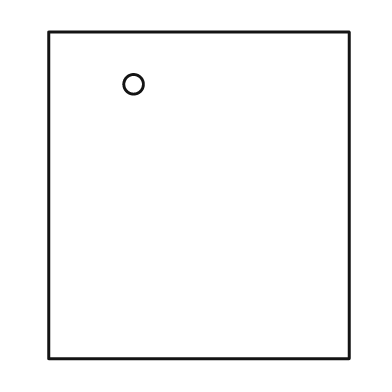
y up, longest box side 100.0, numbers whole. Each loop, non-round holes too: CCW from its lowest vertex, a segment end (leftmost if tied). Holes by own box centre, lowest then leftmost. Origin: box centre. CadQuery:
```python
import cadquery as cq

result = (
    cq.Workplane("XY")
    .moveTo(-46.0, -50.0)
    .lineTo(46.0, -50.0)
    .lineTo(46.0, 50.0)
    .lineTo(-46.0, 50.0)
    .close()
    .moveTo(-20.0, 34.0)
    .circle(3.0)
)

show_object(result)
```